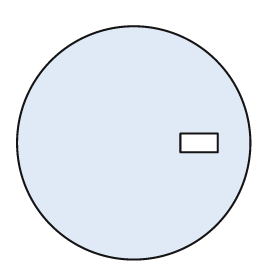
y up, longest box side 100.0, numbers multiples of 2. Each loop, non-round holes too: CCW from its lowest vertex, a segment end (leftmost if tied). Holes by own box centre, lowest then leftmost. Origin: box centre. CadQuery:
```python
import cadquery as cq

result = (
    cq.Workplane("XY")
    .moveTo(0.0, 0.0)
    .circle(50.0)
    .moveTo(20.0, -4.0)
    .lineTo(36.0, -4.0)
    .lineTo(36.0, 4.0)
    .lineTo(20.0, 4.0)
    .close()
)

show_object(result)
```